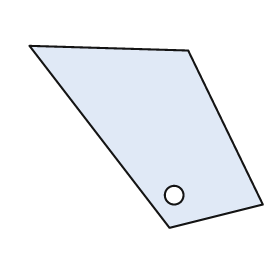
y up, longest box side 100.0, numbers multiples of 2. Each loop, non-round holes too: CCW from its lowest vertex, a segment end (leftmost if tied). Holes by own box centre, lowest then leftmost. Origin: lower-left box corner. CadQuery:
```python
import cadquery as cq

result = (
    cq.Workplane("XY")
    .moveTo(60.0, 0.0)
    .lineTo(100.0, 10.0)
    .lineTo(68.0, 76.0)
    .lineTo(0.0, 78.0)
    .close()
    .moveTo(62.0, 14.0)
    .circle(4.0)
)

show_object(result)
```